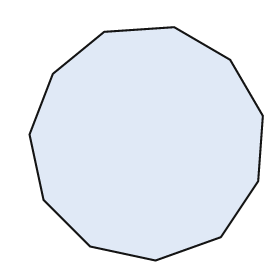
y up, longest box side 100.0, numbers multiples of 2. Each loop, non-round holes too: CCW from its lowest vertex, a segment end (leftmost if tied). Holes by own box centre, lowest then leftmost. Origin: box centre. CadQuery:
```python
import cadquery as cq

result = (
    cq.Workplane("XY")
    .moveTo(4.0, -50.0)
    .lineTo(32.0, -40.0)
    .lineTo(48.0, -16.0)
    .lineTo(50.0, 12.0)
    .lineTo(36.0, 36.0)
    .lineTo(12.0, 50.0)
    .lineTo(-18.0, 48.0)
    .lineTo(-40.0, 30.0)
    .lineTo(-50.0, 4.0)
    .lineTo(-44.0, -24.0)
    .lineTo(-24.0, -44.0)
    .close()
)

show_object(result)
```